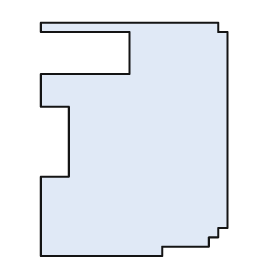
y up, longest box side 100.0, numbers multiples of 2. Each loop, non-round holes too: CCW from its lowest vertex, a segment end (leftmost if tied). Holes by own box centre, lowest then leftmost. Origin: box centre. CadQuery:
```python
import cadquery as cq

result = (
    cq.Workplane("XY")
    .moveTo(-40.0, -50.0)
    .lineTo(12.0, -50.0)
    .lineTo(12.0, -46.0)
    .lineTo(32.0, -46.0)
    .lineTo(32.0, -42.0)
    .lineTo(36.0, -42.0)
    .lineTo(36.0, -38.0)
    .lineTo(40.0, -38.0)
    .lineTo(40.0, 46.0)
    .lineTo(36.0, 46.0)
    .lineTo(36.0, 50.0)
    .lineTo(-40.0, 50.0)
    .lineTo(-40.0, 46.0)
    .lineTo(-2.0, 46.0)
    .lineTo(-2.0, 28.0)
    .lineTo(-40.0, 28.0)
    .lineTo(-40.0, 14.0)
    .lineTo(-28.0, 14.0)
    .lineTo(-28.0, -16.0)
    .lineTo(-40.0, -16.0)
    .close()
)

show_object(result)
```